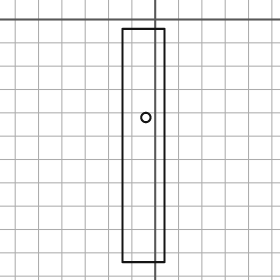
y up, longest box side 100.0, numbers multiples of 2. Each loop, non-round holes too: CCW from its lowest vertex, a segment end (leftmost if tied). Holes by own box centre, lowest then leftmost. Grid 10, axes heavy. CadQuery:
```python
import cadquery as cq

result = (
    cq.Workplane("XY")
    .moveTo(-14.0, -104.0)
    .lineTo(4.0, -104.0)
    .lineTo(4.0, -4.0)
    .lineTo(-14.0, -4.0)
    .close()
    .moveTo(-4.0, -42.0)
    .circle(2.0)
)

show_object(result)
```